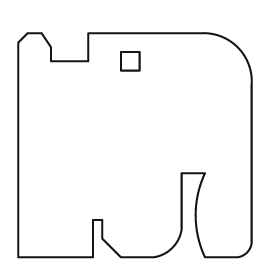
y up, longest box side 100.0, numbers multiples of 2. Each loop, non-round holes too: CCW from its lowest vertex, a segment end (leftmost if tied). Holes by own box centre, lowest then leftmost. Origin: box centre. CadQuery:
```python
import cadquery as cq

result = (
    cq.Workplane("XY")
    .moveTo(-50.0, -48.0)
    .lineTo(-18.0, -48.0)
    .lineTo(-18.0, -32.0)
    .lineTo(-14.0, -32.0)
    .lineTo(-14.0, -40.0)
    .lineTo(-6.0, -48.0)
    .lineTo(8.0, -48.0)
    .threePointArc((16.0, -44.0), (20.0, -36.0))
    .lineTo(20.0, -12.0)
    .lineTo(30.0, -12.0)
    .threePointArc((26.0, -30.0), (30.0, -48.0))
    .lineTo(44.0, -48.0)
    .threePointArc((48.0, -46.0), (50.0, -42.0))
    .lineTo(50.0, 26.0)
    .threePointArc((44.0, 42.0), (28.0, 48.0))
    .lineTo(-20.0, 48.0)
    .lineTo(-20.0, 36.0)
    .lineTo(-36.0, 36.0)
    .lineTo(-36.0, 42.0)
    .lineTo(-40.0, 48.0)
    .lineTo(-46.0, 48.0)
    .lineTo(-50.0, 44.0)
    .close()
    .moveTo(-6.0, 32.0)
    .lineTo(2.0, 32.0)
    .lineTo(2.0, 40.0)
    .lineTo(-6.0, 40.0)
    .close()
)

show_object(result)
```